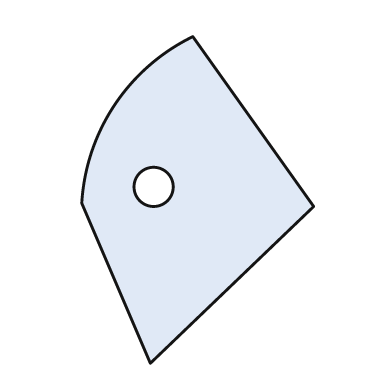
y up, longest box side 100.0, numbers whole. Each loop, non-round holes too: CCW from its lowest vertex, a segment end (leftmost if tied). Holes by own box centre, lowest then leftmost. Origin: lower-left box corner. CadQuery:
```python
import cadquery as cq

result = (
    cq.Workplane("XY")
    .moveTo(21.0, 0.0)
    .lineTo(71.0, 48.0)
    .lineTo(34.0, 100.0)
    .threePointArc((10.0, 79.0), (0.0, 49.0))
    .close()
    .moveTo(22.0, 54.0)
    .circle(6.0)
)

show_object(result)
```